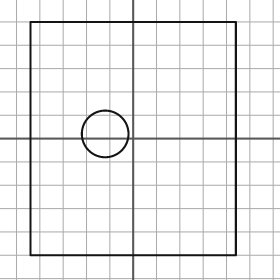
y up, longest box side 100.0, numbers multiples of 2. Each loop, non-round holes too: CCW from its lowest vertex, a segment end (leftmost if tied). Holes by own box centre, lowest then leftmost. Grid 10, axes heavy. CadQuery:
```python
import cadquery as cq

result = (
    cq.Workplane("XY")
    .moveTo(-44.0, -50.0)
    .lineTo(44.0, -50.0)
    .lineTo(44.0, 50.0)
    .lineTo(-44.0, 50.0)
    .close()
    .moveTo(-12.0, 2.0)
    .circle(10.0)
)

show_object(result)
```